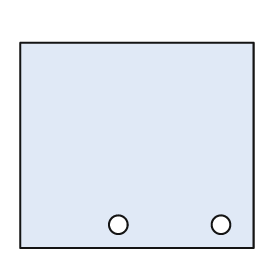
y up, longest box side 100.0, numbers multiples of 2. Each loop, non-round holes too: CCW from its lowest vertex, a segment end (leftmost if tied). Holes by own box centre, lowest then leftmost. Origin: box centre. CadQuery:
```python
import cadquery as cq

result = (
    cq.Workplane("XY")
    .moveTo(-50.0, -44.0)
    .lineTo(50.0, -44.0)
    .lineTo(50.0, 44.0)
    .lineTo(-50.0, 44.0)
    .close()
    .moveTo(-8.0, -34.0)
    .circle(4.0)
    .moveTo(36.0, -34.0)
    .circle(4.0)
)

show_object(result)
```